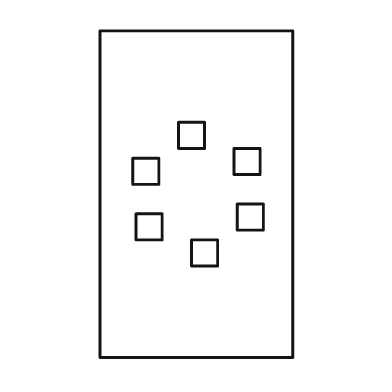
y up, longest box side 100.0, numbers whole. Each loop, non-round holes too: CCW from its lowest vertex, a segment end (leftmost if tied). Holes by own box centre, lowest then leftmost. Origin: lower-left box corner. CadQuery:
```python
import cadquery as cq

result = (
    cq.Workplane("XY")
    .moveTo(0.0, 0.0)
    .lineTo(59.0, 0.0)
    .lineTo(59.0, 100.0)
    .lineTo(0.0, 100.0)
    .close()
    .moveTo(28.0, 28.0)
    .lineTo(36.0, 28.0)
    .lineTo(36.0, 36.0)
    .lineTo(28.0, 36.0)
    .close()
    .moveTo(11.0, 36.0)
    .lineTo(19.0, 36.0)
    .lineTo(19.0, 44.0)
    .lineTo(11.0, 44.0)
    .close()
    .moveTo(42.0, 39.0)
    .lineTo(50.0, 39.0)
    .lineTo(50.0, 47.0)
    .lineTo(42.0, 47.0)
    .close()
    .moveTo(10.0, 53.0)
    .lineTo(18.0, 53.0)
    .lineTo(18.0, 61.0)
    .lineTo(10.0, 61.0)
    .close()
    .moveTo(41.0, 56.0)
    .lineTo(49.0, 56.0)
    .lineTo(49.0, 64.0)
    .lineTo(41.0, 64.0)
    .close()
    .moveTo(24.0, 64.0)
    .lineTo(32.0, 64.0)
    .lineTo(32.0, 72.0)
    .lineTo(24.0, 72.0)
    .close()
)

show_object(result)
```